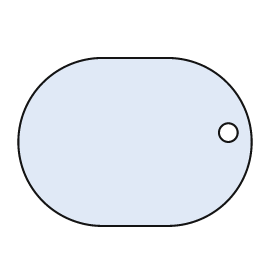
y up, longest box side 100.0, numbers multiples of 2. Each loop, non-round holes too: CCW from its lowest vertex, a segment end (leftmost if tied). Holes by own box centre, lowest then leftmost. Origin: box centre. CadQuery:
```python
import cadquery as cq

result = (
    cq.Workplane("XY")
    .moveTo(-14.0, -36.0)
    .lineTo(14.0, -36.0)
    .threePointArc((50.0, 0.0), (14.0, 36.0))
    .lineTo(-14.0, 36.0)
    .threePointArc((-50.0, 0.0), (-14.0, -36.0))
    .close()
    .moveTo(40.0, 4.0)
    .circle(4.0)
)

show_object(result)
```